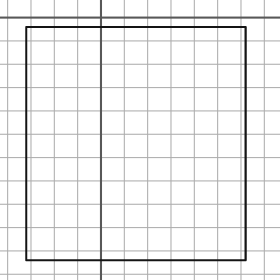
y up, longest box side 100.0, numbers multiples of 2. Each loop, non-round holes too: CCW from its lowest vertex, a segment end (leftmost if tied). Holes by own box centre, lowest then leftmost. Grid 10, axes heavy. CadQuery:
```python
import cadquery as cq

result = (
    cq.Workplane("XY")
    .moveTo(-32.0, -104.0)
    .lineTo(62.0, -104.0)
    .lineTo(62.0, -4.0)
    .lineTo(-32.0, -4.0)
    .close()
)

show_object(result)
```